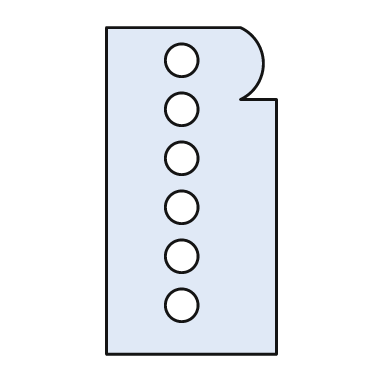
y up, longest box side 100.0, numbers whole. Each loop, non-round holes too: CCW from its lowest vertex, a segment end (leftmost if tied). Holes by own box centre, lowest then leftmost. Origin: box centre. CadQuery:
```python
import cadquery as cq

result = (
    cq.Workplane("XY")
    .moveTo(-26.0, -50.0)
    .lineTo(26.0, -50.0)
    .lineTo(26.0, 28.0)
    .lineTo(15.0, 28.0)
    .threePointArc((22.0, 39.0), (15.0, 50.0))
    .lineTo(-26.0, 50.0)
    .close()
    .moveTo(-3.0, -35.0)
    .circle(5.0)
    .moveTo(-3.0, -20.0)
    .circle(5.0)
    .moveTo(-3.0, -5.0)
    .circle(5.0)
    .moveTo(-3.0, 10.0)
    .circle(5.0)
    .moveTo(-3.0, 25.0)
    .circle(5.0)
    .moveTo(-3.0, 40.0)
    .circle(5.0)
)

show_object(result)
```